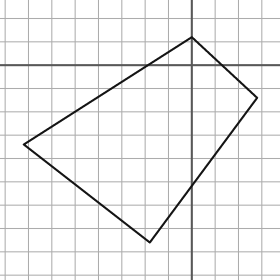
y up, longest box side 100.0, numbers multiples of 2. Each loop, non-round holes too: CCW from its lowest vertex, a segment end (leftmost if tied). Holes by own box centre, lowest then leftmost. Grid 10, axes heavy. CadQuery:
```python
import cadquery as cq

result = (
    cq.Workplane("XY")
    .moveTo(-18.0, -76.0)
    .lineTo(28.0, -14.0)
    .lineTo(0.0, 12.0)
    .lineTo(-72.0, -34.0)
    .close()
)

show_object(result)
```